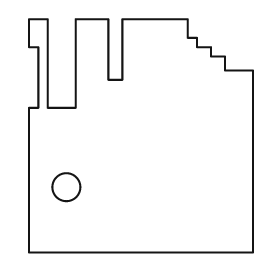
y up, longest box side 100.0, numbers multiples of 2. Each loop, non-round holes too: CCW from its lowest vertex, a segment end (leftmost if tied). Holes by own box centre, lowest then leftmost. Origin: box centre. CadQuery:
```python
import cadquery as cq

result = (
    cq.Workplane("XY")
    .moveTo(-48.0, -50.0)
    .lineTo(48.0, -50.0)
    .lineTo(48.0, 28.0)
    .lineTo(36.0, 28.0)
    .lineTo(36.0, 34.0)
    .lineTo(30.0, 34.0)
    .lineTo(30.0, 38.0)
    .lineTo(24.0, 38.0)
    .lineTo(24.0, 42.0)
    .lineTo(20.0, 42.0)
    .lineTo(20.0, 50.0)
    .lineTo(-8.0, 50.0)
    .lineTo(-8.0, 24.0)
    .lineTo(-14.0, 24.0)
    .lineTo(-14.0, 50.0)
    .lineTo(-28.0, 50.0)
    .lineTo(-28.0, 12.0)
    .lineTo(-40.0, 12.0)
    .lineTo(-40.0, 50.0)
    .lineTo(-48.0, 50.0)
    .lineTo(-48.0, 38.0)
    .lineTo(-44.0, 38.0)
    .lineTo(-44.0, 12.0)
    .lineTo(-48.0, 12.0)
    .close()
    .moveTo(-32.0, -22.0)
    .circle(6.0)
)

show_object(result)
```